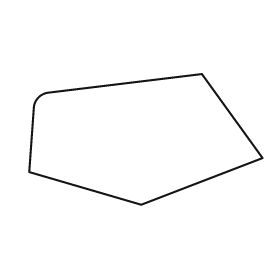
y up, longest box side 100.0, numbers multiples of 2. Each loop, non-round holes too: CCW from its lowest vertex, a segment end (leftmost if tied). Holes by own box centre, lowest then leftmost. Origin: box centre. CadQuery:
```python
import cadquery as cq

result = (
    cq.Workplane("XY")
    .moveTo(-2.0, -28.0)
    .lineTo(50.0, -8.0)
    .lineTo(24.0, 28.0)
    .lineTo(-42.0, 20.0)
    .threePointArc((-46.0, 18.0), (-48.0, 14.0))
    .lineTo(-50.0, -14.0)
    .close()
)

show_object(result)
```